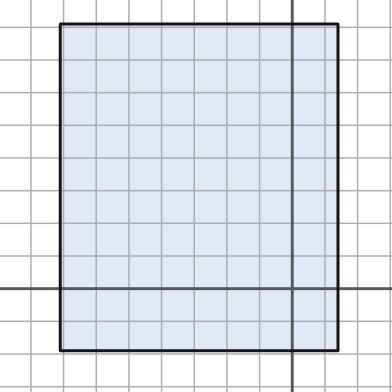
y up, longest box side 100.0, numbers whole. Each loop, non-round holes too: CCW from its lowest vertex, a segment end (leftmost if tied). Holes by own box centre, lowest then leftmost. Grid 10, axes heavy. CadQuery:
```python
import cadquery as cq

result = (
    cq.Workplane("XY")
    .moveTo(-71.0, -19.0)
    .lineTo(14.0, -19.0)
    .lineTo(14.0, 81.0)
    .lineTo(-71.0, 81.0)
    .close()
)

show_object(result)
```